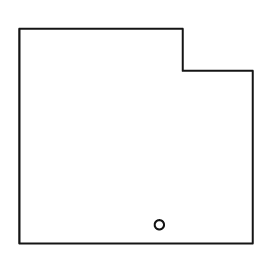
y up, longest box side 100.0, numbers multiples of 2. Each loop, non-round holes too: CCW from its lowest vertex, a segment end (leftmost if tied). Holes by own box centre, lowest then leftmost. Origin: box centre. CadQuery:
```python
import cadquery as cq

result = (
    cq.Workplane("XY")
    .moveTo(-50.0, -46.0)
    .lineTo(50.0, -46.0)
    .lineTo(50.0, 28.0)
    .lineTo(20.0, 28.0)
    .lineTo(20.0, 46.0)
    .lineTo(-50.0, 46.0)
    .close()
    .moveTo(10.0, -38.0)
    .circle(2.0)
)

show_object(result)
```